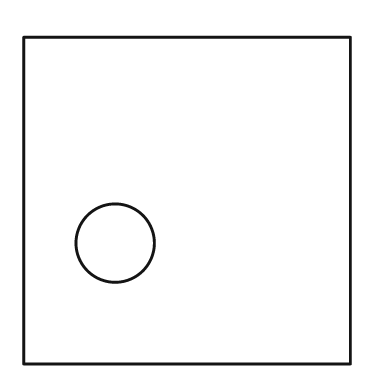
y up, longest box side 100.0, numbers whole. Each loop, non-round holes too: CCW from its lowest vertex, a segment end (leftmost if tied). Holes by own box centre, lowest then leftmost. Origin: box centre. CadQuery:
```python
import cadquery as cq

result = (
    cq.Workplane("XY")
    .moveTo(-50.0, -50.0)
    .lineTo(50.0, -50.0)
    .lineTo(50.0, 50.0)
    .lineTo(-50.0, 50.0)
    .close()
    .moveTo(-22.0, -13.0)
    .circle(12.0)
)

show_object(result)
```